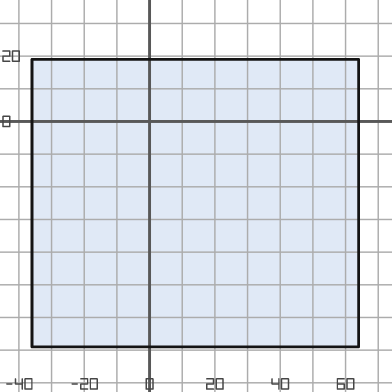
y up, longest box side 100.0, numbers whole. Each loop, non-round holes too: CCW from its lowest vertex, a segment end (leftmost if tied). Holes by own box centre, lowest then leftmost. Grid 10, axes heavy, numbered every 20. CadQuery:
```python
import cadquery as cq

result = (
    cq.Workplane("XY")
    .moveTo(-36.0, -69.0)
    .lineTo(64.0, -69.0)
    .lineTo(64.0, 19.0)
    .lineTo(-36.0, 19.0)
    .close()
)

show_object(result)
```